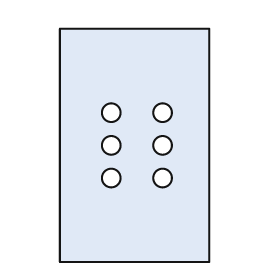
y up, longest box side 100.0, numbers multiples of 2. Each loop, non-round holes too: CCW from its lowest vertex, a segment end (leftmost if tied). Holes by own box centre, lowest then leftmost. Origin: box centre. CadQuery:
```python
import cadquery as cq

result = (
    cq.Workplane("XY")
    .moveTo(-32.0, -50.0)
    .lineTo(32.0, -50.0)
    .lineTo(32.0, 50.0)
    .lineTo(-32.0, 50.0)
    .close()
    .moveTo(-10.0, -14.0)
    .circle(4.0)
    .moveTo(12.0, -14.0)
    .circle(4.0)
    .moveTo(-10.0, 0.0)
    .circle(4.0)
    .moveTo(12.0, 0.0)
    .circle(4.0)
    .moveTo(-10.0, 14.0)
    .circle(4.0)
    .moveTo(12.0, 14.0)
    .circle(4.0)
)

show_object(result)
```